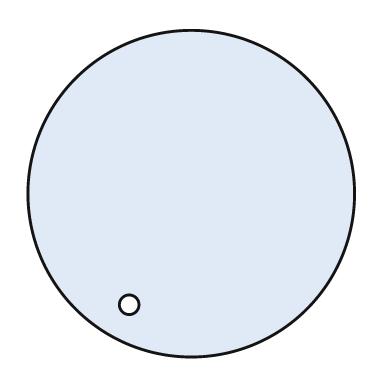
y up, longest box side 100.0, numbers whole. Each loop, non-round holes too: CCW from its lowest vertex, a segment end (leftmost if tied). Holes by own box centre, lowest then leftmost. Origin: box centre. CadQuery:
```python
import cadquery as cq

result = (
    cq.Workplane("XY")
    .moveTo(0.0, 0.0)
    .circle(50.0)
    .moveTo(-19.0, -34.0)
    .circle(3.0)
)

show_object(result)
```